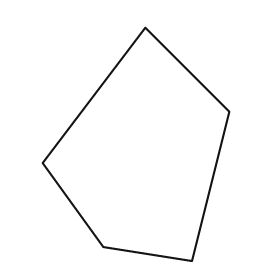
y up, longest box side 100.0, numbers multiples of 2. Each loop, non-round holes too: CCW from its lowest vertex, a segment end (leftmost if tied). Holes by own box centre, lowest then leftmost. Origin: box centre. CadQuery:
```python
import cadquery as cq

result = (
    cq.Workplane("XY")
    .moveTo(24.0, -50.0)
    .lineTo(40.0, 14.0)
    .lineTo(4.0, 50.0)
    .lineTo(-40.0, -8.0)
    .lineTo(-14.0, -44.0)
    .close()
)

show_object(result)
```